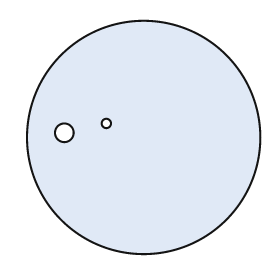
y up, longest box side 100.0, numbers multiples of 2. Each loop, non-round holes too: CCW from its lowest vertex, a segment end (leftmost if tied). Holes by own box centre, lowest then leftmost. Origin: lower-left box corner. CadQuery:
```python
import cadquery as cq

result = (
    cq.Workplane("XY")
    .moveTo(50.0, 50.0)
    .circle(50.0)
    .moveTo(16.0, 52.0)
    .circle(4.0)
    .moveTo(34.0, 56.0)
    .circle(2.0)
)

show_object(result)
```